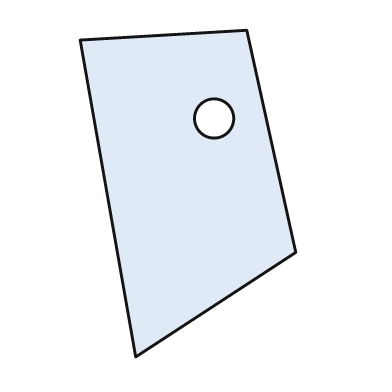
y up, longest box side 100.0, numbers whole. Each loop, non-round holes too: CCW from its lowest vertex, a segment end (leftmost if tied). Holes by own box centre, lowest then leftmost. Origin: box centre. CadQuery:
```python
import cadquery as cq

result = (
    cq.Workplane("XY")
    .moveTo(-16.0, -50.0)
    .lineTo(33.0, -18.0)
    .lineTo(18.0, 50.0)
    .lineTo(-33.0, 47.0)
    .close()
    .moveTo(8.0, 23.0)
    .circle(6.0)
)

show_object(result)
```